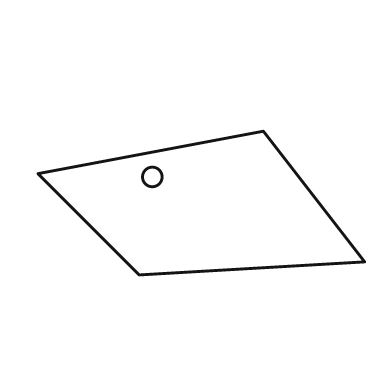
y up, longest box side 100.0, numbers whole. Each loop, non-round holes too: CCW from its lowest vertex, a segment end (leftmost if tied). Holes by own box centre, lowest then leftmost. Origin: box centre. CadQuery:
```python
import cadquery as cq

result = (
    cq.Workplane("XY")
    .moveTo(-19.0, -22.0)
    .lineTo(50.0, -18.0)
    .lineTo(19.0, 22.0)
    .lineTo(-50.0, 9.0)
    .close()
    .moveTo(-15.0, 8.0)
    .circle(3.0)
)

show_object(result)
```